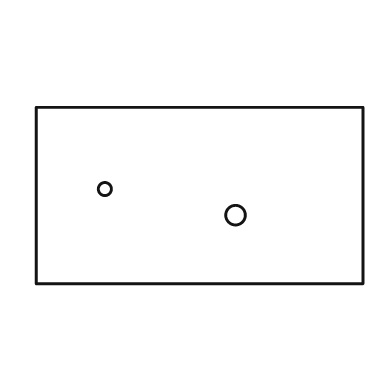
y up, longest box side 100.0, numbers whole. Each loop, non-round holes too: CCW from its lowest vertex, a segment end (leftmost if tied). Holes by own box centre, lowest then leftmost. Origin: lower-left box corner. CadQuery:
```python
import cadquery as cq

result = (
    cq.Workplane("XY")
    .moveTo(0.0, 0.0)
    .lineTo(100.0, 0.0)
    .lineTo(100.0, 54.0)
    .lineTo(0.0, 54.0)
    .close()
    .moveTo(61.0, 21.0)
    .circle(3.0)
    .moveTo(21.0, 29.0)
    .circle(2.0)
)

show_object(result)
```